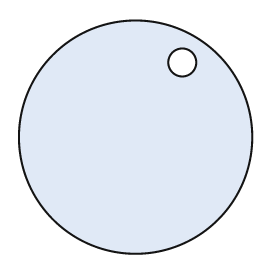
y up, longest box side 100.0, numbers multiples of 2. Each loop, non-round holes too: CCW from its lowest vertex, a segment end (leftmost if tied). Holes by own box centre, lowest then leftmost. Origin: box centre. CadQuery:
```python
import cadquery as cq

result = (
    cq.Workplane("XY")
    .moveTo(0.0, 0.0)
    .circle(50.0)
    .moveTo(20.0, 32.0)
    .circle(6.0)
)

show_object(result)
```